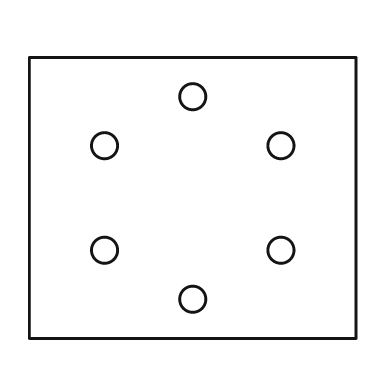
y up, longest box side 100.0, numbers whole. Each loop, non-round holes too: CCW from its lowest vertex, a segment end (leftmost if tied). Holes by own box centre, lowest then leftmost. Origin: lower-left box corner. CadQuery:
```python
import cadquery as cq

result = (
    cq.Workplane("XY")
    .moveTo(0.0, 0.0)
    .lineTo(100.0, 0.0)
    .lineTo(100.0, 86.0)
    .lineTo(0.0, 86.0)
    .close()
    .moveTo(50.0, 12.0)
    .circle(4.0)
    .moveTo(23.0, 27.0)
    .circle(4.0)
    .moveTo(77.0, 27.0)
    .circle(4.0)
    .moveTo(23.0, 59.0)
    .circle(4.0)
    .moveTo(77.0, 59.0)
    .circle(4.0)
    .moveTo(50.0, 74.0)
    .circle(4.0)
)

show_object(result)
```